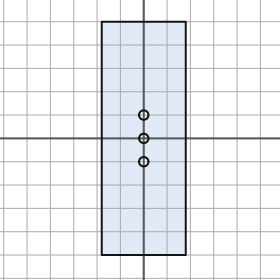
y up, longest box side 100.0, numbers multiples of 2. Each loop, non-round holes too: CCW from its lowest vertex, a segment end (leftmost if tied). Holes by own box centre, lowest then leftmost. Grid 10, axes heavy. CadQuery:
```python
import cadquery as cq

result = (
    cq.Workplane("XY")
    .moveTo(-18.0, -50.0)
    .lineTo(18.0, -50.0)
    .lineTo(18.0, 50.0)
    .lineTo(-18.0, 50.0)
    .close()
    .moveTo(0.0, -10.0)
    .circle(2.0)
    .moveTo(0.0, 0.0)
    .circle(2.0)
    .moveTo(0.0, 10.0)
    .circle(2.0)
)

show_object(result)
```